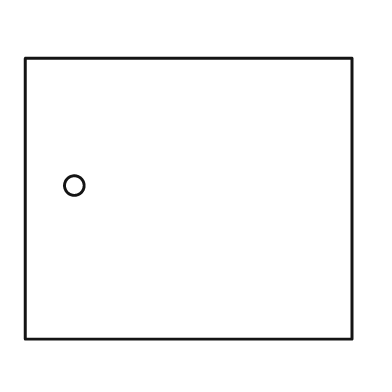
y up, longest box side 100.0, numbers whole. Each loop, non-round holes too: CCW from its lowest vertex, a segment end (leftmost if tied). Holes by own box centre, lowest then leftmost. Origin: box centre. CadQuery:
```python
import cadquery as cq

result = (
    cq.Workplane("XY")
    .moveTo(-50.0, -43.0)
    .lineTo(50.0, -43.0)
    .lineTo(50.0, 43.0)
    .lineTo(-50.0, 43.0)
    .close()
    .moveTo(-35.0, 4.0)
    .circle(3.0)
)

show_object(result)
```